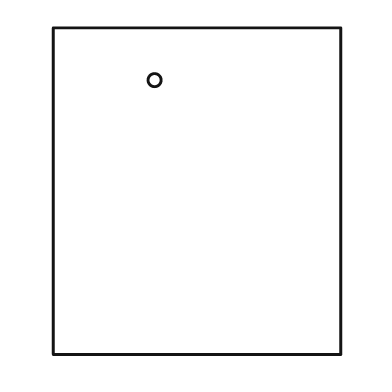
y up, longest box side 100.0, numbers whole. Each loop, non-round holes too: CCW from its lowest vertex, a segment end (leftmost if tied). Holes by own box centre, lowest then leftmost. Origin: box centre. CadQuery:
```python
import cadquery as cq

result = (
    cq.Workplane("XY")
    .moveTo(-44.0, -50.0)
    .lineTo(44.0, -50.0)
    .lineTo(44.0, 50.0)
    .lineTo(-44.0, 50.0)
    .close()
    .moveTo(-13.0, 34.0)
    .circle(2.0)
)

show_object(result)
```